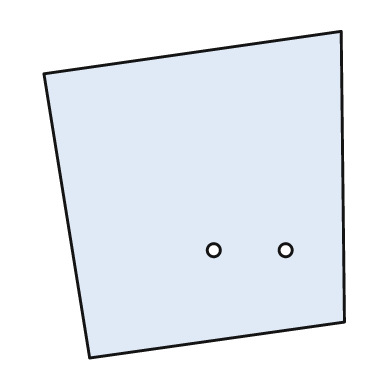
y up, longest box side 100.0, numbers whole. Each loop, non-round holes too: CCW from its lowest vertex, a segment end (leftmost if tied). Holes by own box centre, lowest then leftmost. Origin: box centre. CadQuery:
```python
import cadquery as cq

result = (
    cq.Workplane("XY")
    .moveTo(-32.0, -50.0)
    .lineTo(46.0, -39.0)
    .lineTo(45.0, 50.0)
    .lineTo(-46.0, 37.0)
    .close()
    .moveTo(6.0, -17.0)
    .circle(2.0)
    .moveTo(28.0, -17.0)
    .circle(2.0)
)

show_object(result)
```